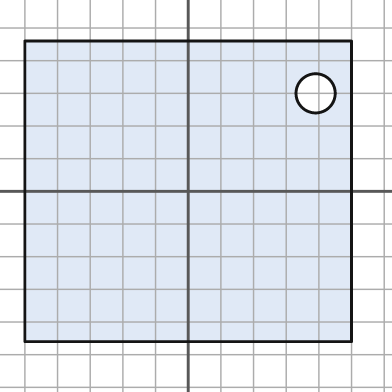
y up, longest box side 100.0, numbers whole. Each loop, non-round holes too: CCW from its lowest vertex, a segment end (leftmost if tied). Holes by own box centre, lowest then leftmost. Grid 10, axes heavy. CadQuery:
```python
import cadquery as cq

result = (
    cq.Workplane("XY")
    .moveTo(-50.0, -46.0)
    .lineTo(50.0, -46.0)
    .lineTo(50.0, 46.0)
    .lineTo(-50.0, 46.0)
    .close()
    .moveTo(39.0, 30.0)
    .circle(6.0)
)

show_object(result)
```